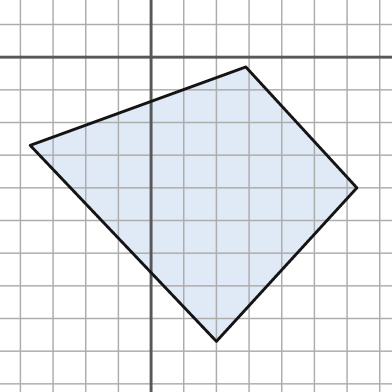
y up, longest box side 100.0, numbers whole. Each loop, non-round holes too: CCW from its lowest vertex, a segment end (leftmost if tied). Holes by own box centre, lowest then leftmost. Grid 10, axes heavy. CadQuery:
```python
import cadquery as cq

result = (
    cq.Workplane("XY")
    .moveTo(20.0, -87.0)
    .lineTo(63.0, -40.0)
    .lineTo(29.0, -3.0)
    .lineTo(-37.0, -27.0)
    .close()
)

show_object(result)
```